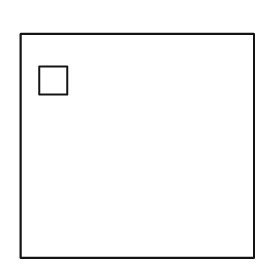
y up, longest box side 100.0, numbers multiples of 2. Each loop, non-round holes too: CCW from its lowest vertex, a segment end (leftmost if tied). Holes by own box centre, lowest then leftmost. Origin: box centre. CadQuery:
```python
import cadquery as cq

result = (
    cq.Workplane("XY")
    .moveTo(-50.0, -48.0)
    .lineTo(50.0, -48.0)
    .lineTo(50.0, 48.0)
    .lineTo(-50.0, 48.0)
    .close()
    .moveTo(-42.0, 22.0)
    .lineTo(-30.0, 22.0)
    .lineTo(-30.0, 34.0)
    .lineTo(-42.0, 34.0)
    .close()
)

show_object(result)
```